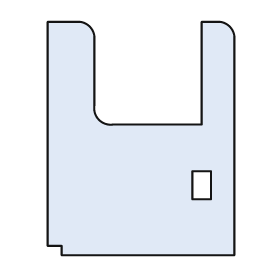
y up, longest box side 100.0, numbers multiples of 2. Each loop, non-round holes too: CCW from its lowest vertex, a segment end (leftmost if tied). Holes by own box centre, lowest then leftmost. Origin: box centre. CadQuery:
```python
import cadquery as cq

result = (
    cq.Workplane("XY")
    .moveTo(-34.0, -50.0)
    .lineTo(40.0, -50.0)
    .lineTo(40.0, 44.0)
    .threePointArc((38.0, 48.0), (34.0, 50.0))
    .lineTo(26.0, 50.0)
    .lineTo(26.0, 6.0)
    .lineTo(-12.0, 6.0)
    .threePointArc((-18.0, 8.0), (-20.0, 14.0))
    .lineTo(-20.0, 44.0)
    .threePointArc((-22.0, 48.0), (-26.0, 50.0))
    .lineTo(-40.0, 50.0)
    .lineTo(-40.0, -46.0)
    .lineTo(-34.0, -46.0)
    .close()
    .moveTo(22.0, -26.0)
    .lineTo(30.0, -26.0)
    .lineTo(30.0, -14.0)
    .lineTo(22.0, -14.0)
    .close()
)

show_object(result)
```